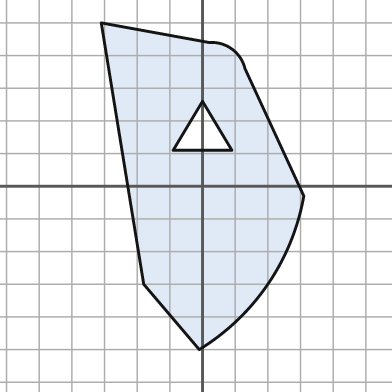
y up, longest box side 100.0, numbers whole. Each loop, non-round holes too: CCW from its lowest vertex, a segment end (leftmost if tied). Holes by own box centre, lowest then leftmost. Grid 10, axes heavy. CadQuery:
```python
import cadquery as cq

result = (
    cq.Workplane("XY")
    .moveTo(-1.0, -50.0)
    .threePointArc((20.0, -30.0), (31.0, -3.0))
    .lineTo(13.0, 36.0)
    .threePointArc((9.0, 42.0), (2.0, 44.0))
    .lineTo(-31.0, 50.0)
    .lineTo(-18.0, -30.0)
    .close()
    .moveTo(-9.0, 11.0)
    .lineTo(9.0, 11.0)
    .lineTo(0.0, 26.0)
    .close()
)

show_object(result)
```